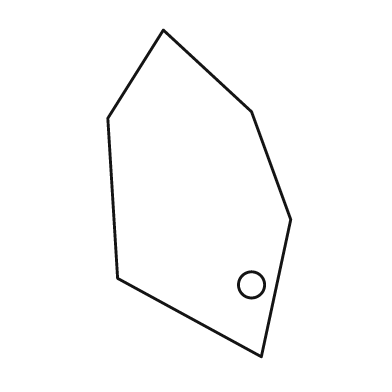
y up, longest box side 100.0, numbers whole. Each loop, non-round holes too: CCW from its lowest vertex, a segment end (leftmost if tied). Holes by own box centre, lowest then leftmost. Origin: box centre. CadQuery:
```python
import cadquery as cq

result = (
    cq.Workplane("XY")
    .moveTo(19.0, -50.0)
    .lineTo(28.0, -8.0)
    .lineTo(16.0, 25.0)
    .lineTo(-11.0, 50.0)
    .lineTo(-28.0, 23.0)
    .lineTo(-25.0, -26.0)
    .close()
    .moveTo(16.0, -28.0)
    .circle(4.0)
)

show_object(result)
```